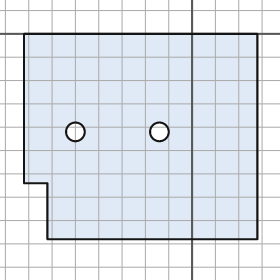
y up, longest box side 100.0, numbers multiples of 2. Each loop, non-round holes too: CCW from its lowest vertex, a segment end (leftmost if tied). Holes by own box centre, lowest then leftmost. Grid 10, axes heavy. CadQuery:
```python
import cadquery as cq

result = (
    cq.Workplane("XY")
    .moveTo(-62.0, -88.0)
    .lineTo(28.0, -88.0)
    .lineTo(28.0, 0.0)
    .lineTo(-72.0, 0.0)
    .lineTo(-72.0, -64.0)
    .lineTo(-62.0, -64.0)
    .close()
    .moveTo(-50.0, -42.0)
    .circle(4.0)
    .moveTo(-14.0, -42.0)
    .circle(4.0)
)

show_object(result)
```